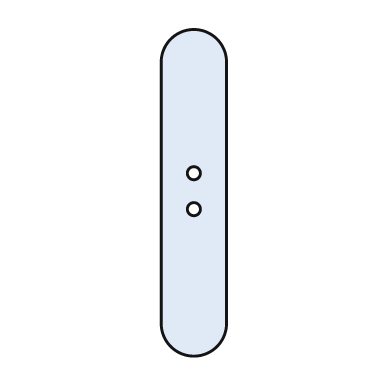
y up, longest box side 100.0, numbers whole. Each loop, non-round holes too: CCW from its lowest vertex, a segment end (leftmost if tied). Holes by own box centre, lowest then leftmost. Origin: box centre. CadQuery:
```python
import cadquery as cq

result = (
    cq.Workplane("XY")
    .moveTo(-10.0, -40.0)
    .threePointArc((0.0, -50.0), (10.0, -40.0))
    .lineTo(10.0, 40.0)
    .threePointArc((0.0, 50.0), (-10.0, 40.0))
    .close()
    .moveTo(0.0, -5.0)
    .circle(2.0)
    .moveTo(0.0, 6.0)
    .circle(2.0)
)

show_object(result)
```